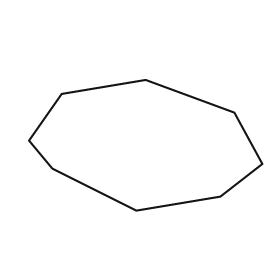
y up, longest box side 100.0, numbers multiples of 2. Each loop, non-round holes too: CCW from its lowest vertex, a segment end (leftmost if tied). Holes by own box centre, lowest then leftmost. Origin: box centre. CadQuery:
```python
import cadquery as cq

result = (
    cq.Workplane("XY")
    .moveTo(-4.0, -28.0)
    .lineTo(32.0, -22.0)
    .lineTo(50.0, -8.0)
    .lineTo(38.0, 14.0)
    .lineTo(0.0, 28.0)
    .lineTo(-36.0, 22.0)
    .lineTo(-50.0, 2.0)
    .lineTo(-40.0, -10.0)
    .close()
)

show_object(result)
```